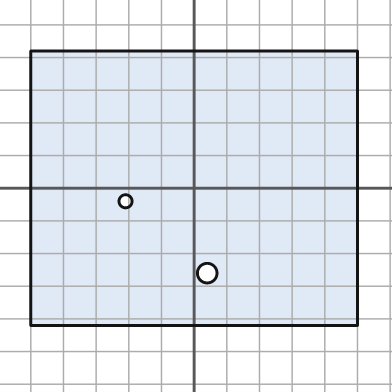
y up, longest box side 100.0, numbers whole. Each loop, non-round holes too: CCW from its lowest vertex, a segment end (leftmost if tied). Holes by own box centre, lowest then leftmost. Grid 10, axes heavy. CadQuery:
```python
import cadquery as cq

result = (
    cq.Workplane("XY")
    .moveTo(-50.0, -42.0)
    .lineTo(50.0, -42.0)
    .lineTo(50.0, 42.0)
    .lineTo(-50.0, 42.0)
    .close()
    .moveTo(4.0, -26.0)
    .circle(3.0)
    .moveTo(-21.0, -4.0)
    .circle(2.0)
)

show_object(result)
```